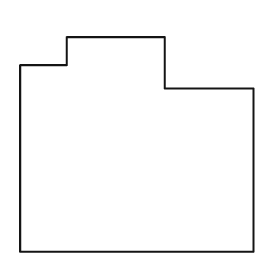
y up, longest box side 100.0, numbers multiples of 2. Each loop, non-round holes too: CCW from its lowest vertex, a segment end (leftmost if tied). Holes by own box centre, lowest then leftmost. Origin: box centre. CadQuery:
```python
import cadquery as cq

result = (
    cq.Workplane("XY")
    .moveTo(-50.0, -46.0)
    .lineTo(50.0, -46.0)
    .lineTo(50.0, 24.0)
    .lineTo(12.0, 24.0)
    .lineTo(12.0, 46.0)
    .lineTo(-30.0, 46.0)
    .lineTo(-30.0, 34.0)
    .lineTo(-50.0, 34.0)
    .close()
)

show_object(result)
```